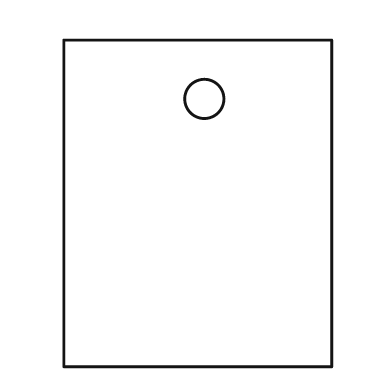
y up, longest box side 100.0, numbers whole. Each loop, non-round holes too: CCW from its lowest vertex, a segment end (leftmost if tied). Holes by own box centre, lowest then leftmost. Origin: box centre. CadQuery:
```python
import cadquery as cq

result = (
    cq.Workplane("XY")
    .moveTo(-41.0, -50.0)
    .lineTo(41.0, -50.0)
    .lineTo(41.0, 50.0)
    .lineTo(-41.0, 50.0)
    .close()
    .moveTo(2.0, 32.0)
    .circle(6.0)
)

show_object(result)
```